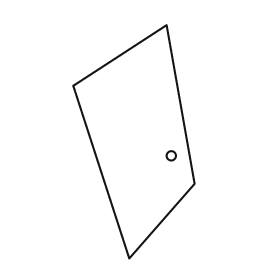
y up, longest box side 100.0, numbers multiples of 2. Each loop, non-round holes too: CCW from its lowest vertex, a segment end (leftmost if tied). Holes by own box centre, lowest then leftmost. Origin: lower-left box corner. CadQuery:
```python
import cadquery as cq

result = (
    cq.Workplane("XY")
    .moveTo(24.0, 0.0)
    .lineTo(52.0, 32.0)
    .lineTo(40.0, 100.0)
    .lineTo(0.0, 74.0)
    .close()
    .moveTo(42.0, 44.0)
    .circle(2.0)
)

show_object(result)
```